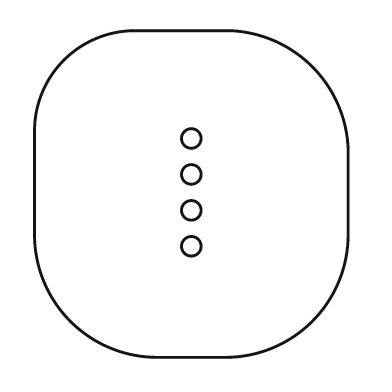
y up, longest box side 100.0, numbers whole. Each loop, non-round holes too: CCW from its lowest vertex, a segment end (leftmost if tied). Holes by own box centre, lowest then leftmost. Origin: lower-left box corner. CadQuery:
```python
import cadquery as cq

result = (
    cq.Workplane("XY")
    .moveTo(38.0, 0.0)
    .lineTo(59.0, 0.0)
    .threePointArc((85.0, 11.0), (96.0, 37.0))
    .lineTo(96.0, 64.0)
    .threePointArc((85.0, 89.0), (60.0, 100.0))
    .lineTo(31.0, 100.0)
    .threePointArc((9.0, 91.0), (0.0, 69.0))
    .lineTo(0.0, 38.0)
    .threePointArc((11.0, 11.0), (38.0, 0.0))
    .close()
    .moveTo(48.0, 34.0)
    .circle(3.0)
    .moveTo(48.0, 45.0)
    .circle(3.0)
    .moveTo(48.0, 56.0)
    .circle(3.0)
    .moveTo(48.0, 67.0)
    .circle(3.0)
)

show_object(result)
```